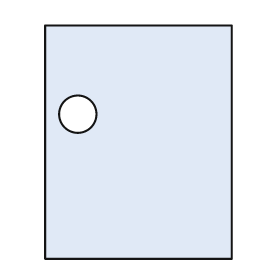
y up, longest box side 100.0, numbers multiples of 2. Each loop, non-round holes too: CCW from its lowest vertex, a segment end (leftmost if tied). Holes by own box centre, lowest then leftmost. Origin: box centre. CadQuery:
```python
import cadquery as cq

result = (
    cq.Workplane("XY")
    .moveTo(-40.0, -50.0)
    .lineTo(40.0, -50.0)
    .lineTo(40.0, 50.0)
    .lineTo(-40.0, 50.0)
    .close()
    .moveTo(-26.0, 12.0)
    .circle(8.0)
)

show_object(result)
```